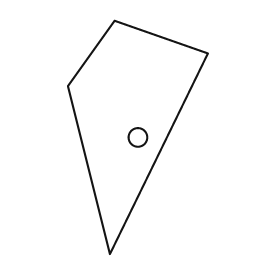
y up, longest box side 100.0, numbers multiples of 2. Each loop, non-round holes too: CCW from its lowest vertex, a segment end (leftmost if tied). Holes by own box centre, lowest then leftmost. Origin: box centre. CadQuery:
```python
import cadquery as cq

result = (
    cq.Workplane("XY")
    .moveTo(-12.0, -50.0)
    .lineTo(30.0, 36.0)
    .lineTo(-10.0, 50.0)
    .lineTo(-30.0, 22.0)
    .close()
    .moveTo(0.0, 0.0)
    .circle(4.0)
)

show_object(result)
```